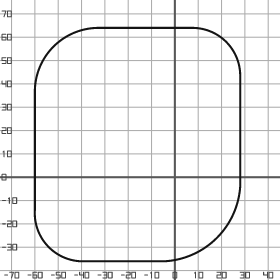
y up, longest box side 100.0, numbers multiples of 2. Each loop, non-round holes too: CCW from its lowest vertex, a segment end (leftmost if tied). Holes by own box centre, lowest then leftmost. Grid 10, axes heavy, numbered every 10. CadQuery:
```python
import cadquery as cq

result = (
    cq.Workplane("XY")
    .moveTo(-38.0, -36.0)
    .lineTo(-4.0, -36.0)
    .threePointArc((18.0, -26.0), (28.0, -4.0))
    .lineTo(28.0, 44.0)
    .threePointArc((22.0, 58.0), (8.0, 64.0))
    .lineTo(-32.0, 64.0)
    .threePointArc((-52.0, 56.0), (-60.0, 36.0))
    .lineTo(-60.0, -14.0)
    .threePointArc((-54.0, -30.0), (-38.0, -36.0))
    .close()
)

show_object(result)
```